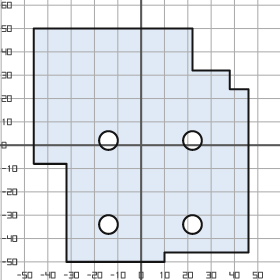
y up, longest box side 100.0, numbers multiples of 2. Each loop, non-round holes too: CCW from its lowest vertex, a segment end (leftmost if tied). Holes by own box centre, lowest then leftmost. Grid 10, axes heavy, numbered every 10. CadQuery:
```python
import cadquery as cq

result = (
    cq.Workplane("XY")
    .moveTo(-32.0, -50.0)
    .lineTo(10.0, -50.0)
    .lineTo(10.0, -46.0)
    .lineTo(46.0, -46.0)
    .lineTo(46.0, 24.0)
    .lineTo(38.0, 24.0)
    .lineTo(38.0, 32.0)
    .lineTo(22.0, 32.0)
    .lineTo(22.0, 50.0)
    .lineTo(-46.0, 50.0)
    .lineTo(-46.0, -8.0)
    .lineTo(-32.0, -8.0)
    .close()
    .moveTo(-14.0, -34.0)
    .circle(4.0)
    .moveTo(22.0, -34.0)
    .circle(4.0)
    .moveTo(-14.0, 2.0)
    .circle(4.0)
    .moveTo(22.0, 2.0)
    .circle(4.0)
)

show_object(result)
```